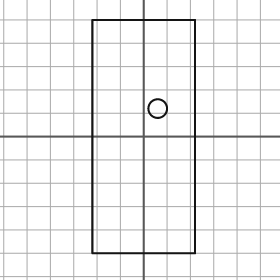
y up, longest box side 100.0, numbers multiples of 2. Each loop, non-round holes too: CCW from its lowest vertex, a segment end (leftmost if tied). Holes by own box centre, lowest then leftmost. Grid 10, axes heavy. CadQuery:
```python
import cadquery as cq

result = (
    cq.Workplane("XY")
    .moveTo(-22.0, -50.0)
    .lineTo(22.0, -50.0)
    .lineTo(22.0, 50.0)
    .lineTo(-22.0, 50.0)
    .close()
    .moveTo(6.0, 12.0)
    .circle(4.0)
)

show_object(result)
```